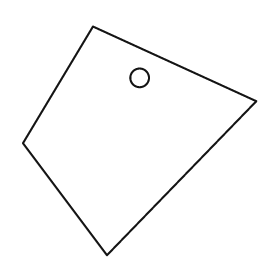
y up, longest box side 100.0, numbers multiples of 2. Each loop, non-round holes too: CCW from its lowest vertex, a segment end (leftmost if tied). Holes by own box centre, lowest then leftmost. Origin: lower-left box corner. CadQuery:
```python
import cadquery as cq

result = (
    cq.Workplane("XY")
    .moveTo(36.0, 0.0)
    .lineTo(100.0, 66.0)
    .lineTo(30.0, 98.0)
    .lineTo(0.0, 48.0)
    .close()
    .moveTo(50.0, 76.0)
    .circle(4.0)
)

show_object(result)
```